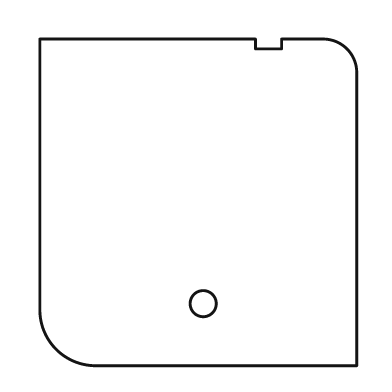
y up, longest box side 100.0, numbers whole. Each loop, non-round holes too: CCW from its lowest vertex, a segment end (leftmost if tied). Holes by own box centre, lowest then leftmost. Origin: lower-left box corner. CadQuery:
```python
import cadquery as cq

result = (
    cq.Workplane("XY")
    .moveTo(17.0, 0.0)
    .lineTo(97.0, 0.0)
    .lineTo(97.0, 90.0)
    .threePointArc((94.0, 97.0), (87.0, 100.0))
    .lineTo(74.0, 100.0)
    .lineTo(74.0, 97.0)
    .lineTo(66.0, 97.0)
    .lineTo(66.0, 100.0)
    .lineTo(0.0, 100.0)
    .lineTo(0.0, 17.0)
    .threePointArc((5.0, 5.0), (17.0, 0.0))
    .close()
    .moveTo(50.0, 19.0)
    .circle(4.0)
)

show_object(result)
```